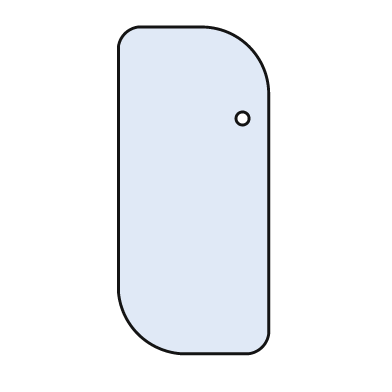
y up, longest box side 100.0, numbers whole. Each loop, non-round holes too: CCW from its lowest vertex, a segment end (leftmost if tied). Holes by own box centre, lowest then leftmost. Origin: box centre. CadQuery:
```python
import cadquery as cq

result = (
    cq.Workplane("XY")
    .moveTo(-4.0, -50.0)
    .lineTo(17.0, -50.0)
    .threePointArc((21.0, -48.0), (23.0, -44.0))
    .lineTo(23.0, 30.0)
    .threePointArc((17.0, 44.0), (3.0, 50.0))
    .lineTo(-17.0, 50.0)
    .threePointArc((-21.0, 48.0), (-23.0, 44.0))
    .lineTo(-23.0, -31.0)
    .threePointArc((-17.0, -44.0), (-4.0, -50.0))
    .close()
    .moveTo(15.0, 22.0)
    .circle(2.0)
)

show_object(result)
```